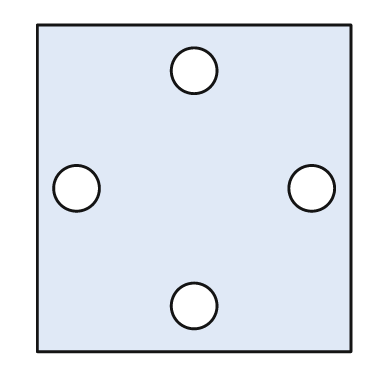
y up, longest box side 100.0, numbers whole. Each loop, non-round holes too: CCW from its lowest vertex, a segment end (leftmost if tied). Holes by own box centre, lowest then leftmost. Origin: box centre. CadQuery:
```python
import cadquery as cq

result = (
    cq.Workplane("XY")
    .moveTo(-48.0, -50.0)
    .lineTo(48.0, -50.0)
    .lineTo(48.0, 50.0)
    .lineTo(-48.0, 50.0)
    .close()
    .moveTo(0.0, -36.0)
    .circle(7.0)
    .moveTo(-36.0, 0.0)
    .circle(7.0)
    .moveTo(36.0, 0.0)
    .circle(7.0)
    .moveTo(0.0, 36.0)
    .circle(7.0)
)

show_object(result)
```